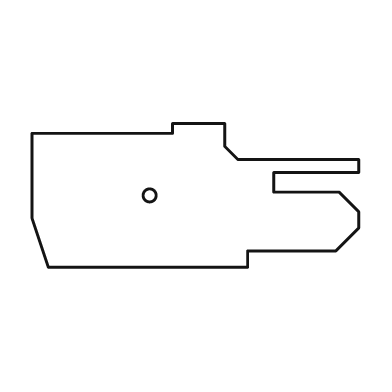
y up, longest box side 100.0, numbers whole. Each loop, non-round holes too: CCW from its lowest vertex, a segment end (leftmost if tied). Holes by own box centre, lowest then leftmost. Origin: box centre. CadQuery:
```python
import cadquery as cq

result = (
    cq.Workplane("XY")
    .moveTo(-45.0, -22.0)
    .lineTo(16.0, -22.0)
    .lineTo(16.0, -17.0)
    .lineTo(43.0, -17.0)
    .lineTo(50.0, -10.0)
    .lineTo(50.0, -5.0)
    .lineTo(44.0, 1.0)
    .lineTo(24.0, 1.0)
    .lineTo(24.0, 7.0)
    .lineTo(50.0, 7.0)
    .lineTo(50.0, 11.0)
    .lineTo(13.0, 11.0)
    .lineTo(9.0, 15.0)
    .lineTo(9.0, 22.0)
    .lineTo(-7.0, 22.0)
    .lineTo(-7.0, 19.0)
    .lineTo(-50.0, 19.0)
    .lineTo(-50.0, -7.0)
    .close()
    .moveTo(-14.0, 0.0)
    .circle(2.0)
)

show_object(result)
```